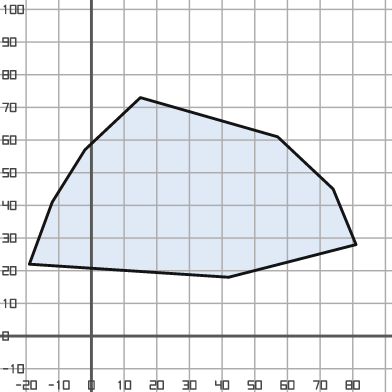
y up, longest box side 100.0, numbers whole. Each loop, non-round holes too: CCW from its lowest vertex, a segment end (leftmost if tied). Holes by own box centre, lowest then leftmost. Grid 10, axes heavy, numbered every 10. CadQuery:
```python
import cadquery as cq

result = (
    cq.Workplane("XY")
    .moveTo(42.0, 18.0)
    .lineTo(81.0, 28.0)
    .lineTo(74.0, 45.0)
    .lineTo(57.0, 61.0)
    .lineTo(15.0, 73.0)
    .lineTo(-2.0, 57.0)
    .lineTo(-12.0, 41.0)
    .lineTo(-19.0, 22.0)
    .close()
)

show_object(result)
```